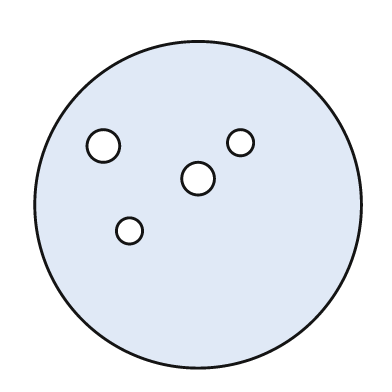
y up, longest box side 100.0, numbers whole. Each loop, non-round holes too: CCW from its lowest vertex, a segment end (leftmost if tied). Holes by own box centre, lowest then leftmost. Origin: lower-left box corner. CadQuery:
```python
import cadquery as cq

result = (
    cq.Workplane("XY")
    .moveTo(50.0, 50.0)
    .circle(50.0)
    .moveTo(29.0, 42.0)
    .circle(4.0)
    .moveTo(50.0, 58.0)
    .circle(5.0)
    .moveTo(21.0, 68.0)
    .circle(5.0)
    .moveTo(63.0, 69.0)
    .circle(4.0)
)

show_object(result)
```